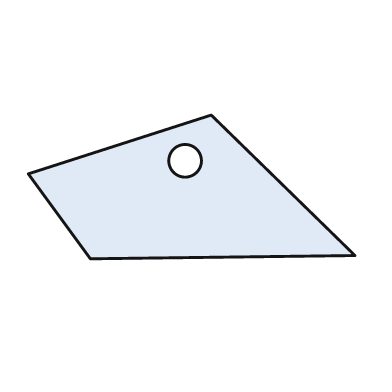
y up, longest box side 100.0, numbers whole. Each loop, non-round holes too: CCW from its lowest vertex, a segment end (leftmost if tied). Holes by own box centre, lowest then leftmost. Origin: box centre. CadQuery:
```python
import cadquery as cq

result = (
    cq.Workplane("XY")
    .moveTo(-31.0, -22.0)
    .lineTo(50.0, -21.0)
    .lineTo(6.0, 22.0)
    .lineTo(-50.0, 4.0)
    .close()
    .moveTo(-2.0, 8.0)
    .circle(5.0)
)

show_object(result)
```